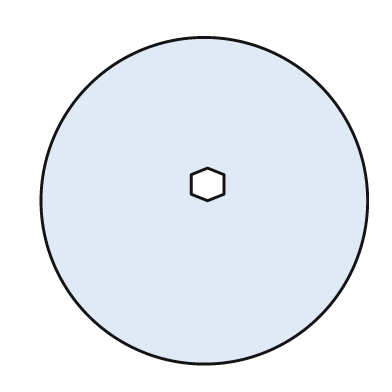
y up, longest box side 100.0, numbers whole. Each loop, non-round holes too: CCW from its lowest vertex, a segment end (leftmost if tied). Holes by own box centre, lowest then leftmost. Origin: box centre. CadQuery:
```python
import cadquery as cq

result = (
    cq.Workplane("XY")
    .moveTo(0.0, 0.0)
    .circle(50.0)
    .moveTo(1.0, 0.0)
    .lineTo(6.0, 2.0)
    .lineTo(6.0, 8.0)
    .lineTo(1.0, 10.0)
    .lineTo(-4.0, 8.0)
    .lineTo(-4.0, 2.0)
    .close()
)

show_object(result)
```